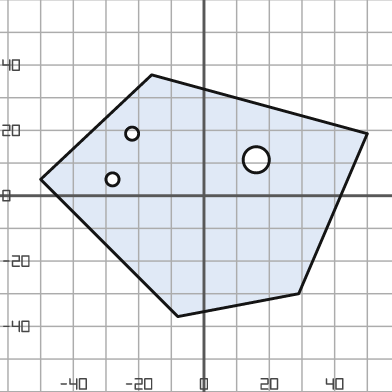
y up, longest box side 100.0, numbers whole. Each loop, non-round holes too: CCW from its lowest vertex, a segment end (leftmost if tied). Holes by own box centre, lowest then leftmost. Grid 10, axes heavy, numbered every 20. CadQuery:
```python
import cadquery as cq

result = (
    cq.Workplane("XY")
    .moveTo(-8.0, -37.0)
    .lineTo(29.0, -30.0)
    .lineTo(50.0, 19.0)
    .lineTo(-16.0, 37.0)
    .lineTo(-50.0, 5.0)
    .close()
    .moveTo(-28.0, 5.0)
    .circle(2.0)
    .moveTo(16.0, 11.0)
    .circle(4.0)
    .moveTo(-22.0, 19.0)
    .circle(2.0)
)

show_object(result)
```